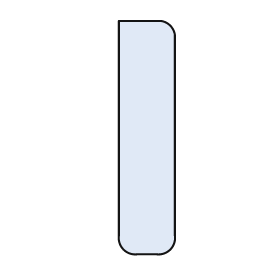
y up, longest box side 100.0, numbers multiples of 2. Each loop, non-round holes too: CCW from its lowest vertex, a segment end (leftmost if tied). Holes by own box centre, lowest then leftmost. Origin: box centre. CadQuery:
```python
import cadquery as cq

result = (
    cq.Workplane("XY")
    .moveTo(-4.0, -50.0)
    .lineTo(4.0, -50.0)
    .threePointArc((10.0, -48.0), (12.0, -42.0))
    .lineTo(12.0, 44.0)
    .threePointArc((10.0, 48.0), (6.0, 50.0))
    .lineTo(-12.0, 50.0)
    .lineTo(-12.0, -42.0)
    .threePointArc((-10.0, -48.0), (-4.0, -50.0))
    .close()
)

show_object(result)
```